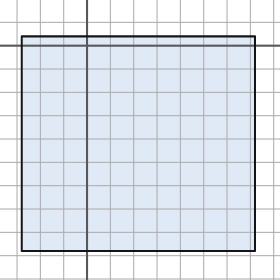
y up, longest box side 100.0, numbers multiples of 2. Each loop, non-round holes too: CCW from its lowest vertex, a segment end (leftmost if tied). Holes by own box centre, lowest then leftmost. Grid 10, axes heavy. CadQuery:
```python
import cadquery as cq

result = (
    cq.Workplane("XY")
    .moveTo(-28.0, -88.0)
    .lineTo(72.0, -88.0)
    .lineTo(72.0, 4.0)
    .lineTo(-28.0, 4.0)
    .close()
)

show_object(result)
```